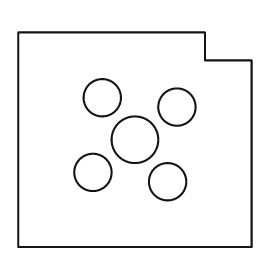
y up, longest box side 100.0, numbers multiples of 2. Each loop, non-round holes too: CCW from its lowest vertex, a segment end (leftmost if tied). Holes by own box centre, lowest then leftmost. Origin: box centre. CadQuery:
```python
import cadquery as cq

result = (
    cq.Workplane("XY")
    .moveTo(-50.0, -46.0)
    .lineTo(50.0, -46.0)
    .lineTo(50.0, 34.0)
    .lineTo(30.0, 34.0)
    .lineTo(30.0, 46.0)
    .lineTo(-50.0, 46.0)
    .close()
    .moveTo(14.0, -18.0)
    .circle(8.0)
    .moveTo(-18.0, -14.0)
    .circle(8.0)
    .moveTo(0.0, 0.0)
    .circle(10.0)
    .moveTo(18.0, 14.0)
    .circle(8.0)
    .moveTo(-14.0, 18.0)
    .circle(8.0)
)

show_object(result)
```